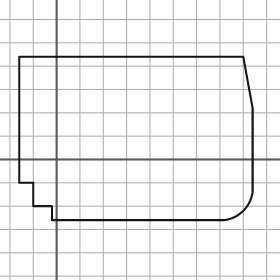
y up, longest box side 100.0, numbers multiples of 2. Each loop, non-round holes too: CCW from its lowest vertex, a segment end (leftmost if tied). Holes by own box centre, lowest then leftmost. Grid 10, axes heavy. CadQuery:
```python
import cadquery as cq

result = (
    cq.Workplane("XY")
    .moveTo(-2.0, -26.0)
    .lineTo(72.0, -26.0)
    .threePointArc((80.0, -22.0), (84.0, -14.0))
    .lineTo(84.0, 22.0)
    .lineTo(80.0, 44.0)
    .lineTo(-16.0, 44.0)
    .lineTo(-16.0, -10.0)
    .lineTo(-10.0, -10.0)
    .lineTo(-10.0, -20.0)
    .lineTo(-2.0, -20.0)
    .close()
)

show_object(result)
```